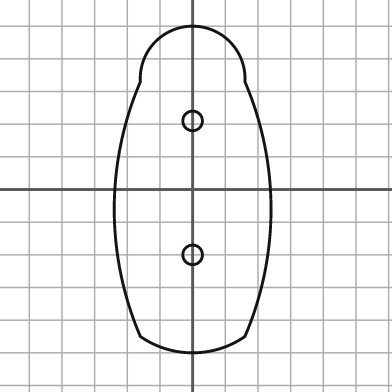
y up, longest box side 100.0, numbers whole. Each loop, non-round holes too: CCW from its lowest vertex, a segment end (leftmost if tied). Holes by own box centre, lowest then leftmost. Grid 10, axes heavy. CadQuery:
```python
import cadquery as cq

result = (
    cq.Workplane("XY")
    .moveTo(-16.0, -45.0)
    .threePointArc((0.0, -50.0), (16.0, -45.0))
    .threePointArc((24.0, -6.0), (16.0, 33.0))
    .threePointArc((0.0, 50.0), (-16.0, 33.0))
    .threePointArc((-24.0, -6.0), (-16.0, -45.0))
    .close()
    .moveTo(0.0, -20.0)
    .circle(3.0)
    .moveTo(0.0, 21.0)
    .circle(3.0)
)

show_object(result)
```